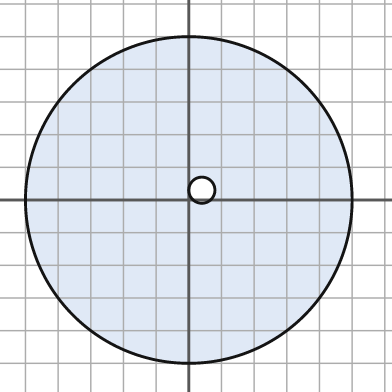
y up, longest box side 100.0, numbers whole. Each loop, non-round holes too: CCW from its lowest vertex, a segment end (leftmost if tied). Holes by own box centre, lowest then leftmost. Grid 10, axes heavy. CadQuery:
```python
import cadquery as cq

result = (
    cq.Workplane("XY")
    .moveTo(0.0, 0.0)
    .circle(50.0)
    .moveTo(4.0, 3.0)
    .circle(4.0)
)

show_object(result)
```